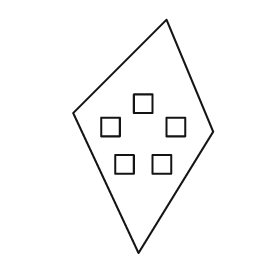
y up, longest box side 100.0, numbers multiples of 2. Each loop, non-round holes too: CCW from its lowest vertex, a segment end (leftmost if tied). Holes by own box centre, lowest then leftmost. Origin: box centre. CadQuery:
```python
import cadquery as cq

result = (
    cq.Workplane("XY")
    .moveTo(-2.0, -50.0)
    .lineTo(30.0, 2.0)
    .lineTo(10.0, 50.0)
    .lineTo(-30.0, 10.0)
    .close()
    .moveTo(-12.0, -16.0)
    .lineTo(-4.0, -16.0)
    .lineTo(-4.0, -8.0)
    .lineTo(-12.0, -8.0)
    .close()
    .moveTo(4.0, -16.0)
    .lineTo(12.0, -16.0)
    .lineTo(12.0, -8.0)
    .lineTo(4.0, -8.0)
    .close()
    .moveTo(-18.0, 0.0)
    .lineTo(-10.0, 0.0)
    .lineTo(-10.0, 8.0)
    .lineTo(-18.0, 8.0)
    .close()
    .moveTo(10.0, 0.0)
    .lineTo(18.0, 0.0)
    .lineTo(18.0, 8.0)
    .lineTo(10.0, 8.0)
    .close()
    .moveTo(-4.0, 10.0)
    .lineTo(4.0, 10.0)
    .lineTo(4.0, 18.0)
    .lineTo(-4.0, 18.0)
    .close()
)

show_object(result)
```